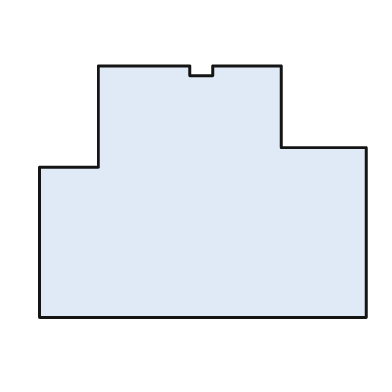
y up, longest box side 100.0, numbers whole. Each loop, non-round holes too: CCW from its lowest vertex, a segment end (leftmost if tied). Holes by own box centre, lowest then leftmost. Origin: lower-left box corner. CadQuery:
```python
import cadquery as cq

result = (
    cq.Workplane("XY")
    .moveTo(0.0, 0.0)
    .lineTo(100.0, 0.0)
    .lineTo(100.0, 52.0)
    .lineTo(74.0, 52.0)
    .lineTo(74.0, 77.0)
    .lineTo(53.0, 77.0)
    .lineTo(53.0, 74.0)
    .lineTo(46.0, 74.0)
    .lineTo(46.0, 77.0)
    .lineTo(18.0, 77.0)
    .lineTo(18.0, 46.0)
    .lineTo(0.0, 46.0)
    .close()
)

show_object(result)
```